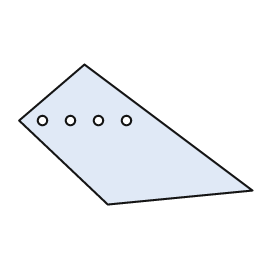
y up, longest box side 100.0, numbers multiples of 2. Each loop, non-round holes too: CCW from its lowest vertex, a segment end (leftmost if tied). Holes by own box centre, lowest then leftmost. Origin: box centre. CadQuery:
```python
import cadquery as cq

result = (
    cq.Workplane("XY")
    .moveTo(-12.0, -30.0)
    .lineTo(50.0, -24.0)
    .lineTo(-22.0, 30.0)
    .lineTo(-50.0, 6.0)
    .close()
    .moveTo(-40.0, 6.0)
    .circle(2.0)
    .moveTo(-28.0, 6.0)
    .circle(2.0)
    .moveTo(-16.0, 6.0)
    .circle(2.0)
    .moveTo(-4.0, 6.0)
    .circle(2.0)
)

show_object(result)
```